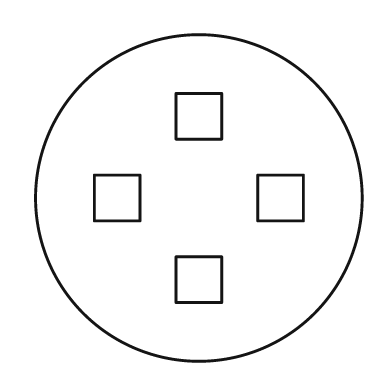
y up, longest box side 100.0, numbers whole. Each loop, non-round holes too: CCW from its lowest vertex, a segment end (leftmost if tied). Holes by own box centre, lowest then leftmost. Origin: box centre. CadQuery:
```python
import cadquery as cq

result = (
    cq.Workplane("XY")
    .moveTo(0.0, 0.0)
    .circle(50.0)
    .moveTo(-7.0, -32.0)
    .lineTo(7.0, -32.0)
    .lineTo(7.0, -18.0)
    .lineTo(-7.0, -18.0)
    .close()
    .moveTo(-32.0, -7.0)
    .lineTo(-18.0, -7.0)
    .lineTo(-18.0, 7.0)
    .lineTo(-32.0, 7.0)
    .close()
    .moveTo(18.0, -7.0)
    .lineTo(32.0, -7.0)
    .lineTo(32.0, 7.0)
    .lineTo(18.0, 7.0)
    .close()
    .moveTo(-7.0, 18.0)
    .lineTo(7.0, 18.0)
    .lineTo(7.0, 32.0)
    .lineTo(-7.0, 32.0)
    .close()
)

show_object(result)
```